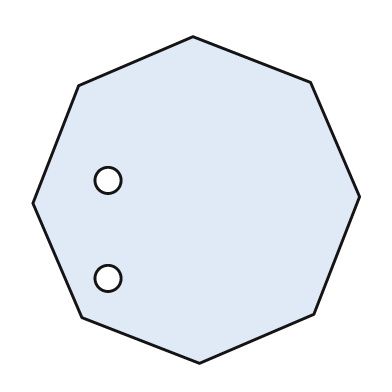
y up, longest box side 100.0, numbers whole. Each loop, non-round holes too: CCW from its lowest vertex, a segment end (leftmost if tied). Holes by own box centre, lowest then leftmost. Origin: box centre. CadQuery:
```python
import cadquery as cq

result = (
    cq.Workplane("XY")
    .moveTo(1.0, -50.0)
    .lineTo(36.0, -35.0)
    .lineTo(50.0, 1.0)
    .lineTo(35.0, 36.0)
    .lineTo(-1.0, 50.0)
    .lineTo(-36.0, 35.0)
    .lineTo(-50.0, -1.0)
    .lineTo(-35.0, -36.0)
    .close()
    .moveTo(-27.0, -24.0)
    .circle(4.0)
    .moveTo(-27.0, 6.0)
    .circle(4.0)
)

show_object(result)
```